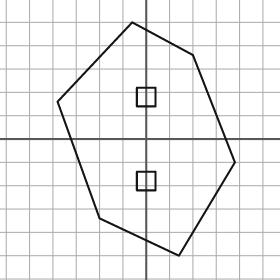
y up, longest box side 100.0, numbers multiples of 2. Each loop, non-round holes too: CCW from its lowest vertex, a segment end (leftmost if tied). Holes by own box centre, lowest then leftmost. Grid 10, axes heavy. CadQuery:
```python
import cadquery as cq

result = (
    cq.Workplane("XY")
    .moveTo(14.0, -50.0)
    .lineTo(38.0, -10.0)
    .lineTo(20.0, 36.0)
    .lineTo(-6.0, 50.0)
    .lineTo(-38.0, 16.0)
    .lineTo(-20.0, -34.0)
    .close()
    .moveTo(-4.0, -22.0)
    .lineTo(4.0, -22.0)
    .lineTo(4.0, -14.0)
    .lineTo(-4.0, -14.0)
    .close()
    .moveTo(-4.0, 14.0)
    .lineTo(4.0, 14.0)
    .lineTo(4.0, 22.0)
    .lineTo(-4.0, 22.0)
    .close()
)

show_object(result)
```